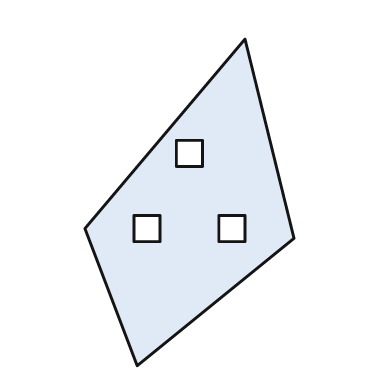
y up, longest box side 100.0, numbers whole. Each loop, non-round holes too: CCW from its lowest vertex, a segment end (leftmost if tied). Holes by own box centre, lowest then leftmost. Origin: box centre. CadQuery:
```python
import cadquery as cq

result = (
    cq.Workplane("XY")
    .moveTo(-16.0, -50.0)
    .lineTo(32.0, -11.0)
    .lineTo(17.0, 50.0)
    .lineTo(-32.0, -8.0)
    .close()
    .moveTo(-17.0, -12.0)
    .lineTo(-9.0, -12.0)
    .lineTo(-9.0, -4.0)
    .lineTo(-17.0, -4.0)
    .close()
    .moveTo(9.0, -12.0)
    .lineTo(17.0, -12.0)
    .lineTo(17.0, -4.0)
    .lineTo(9.0, -4.0)
    .close()
    .moveTo(-4.0, 11.0)
    .lineTo(4.0, 11.0)
    .lineTo(4.0, 19.0)
    .lineTo(-4.0, 19.0)
    .close()
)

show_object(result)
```